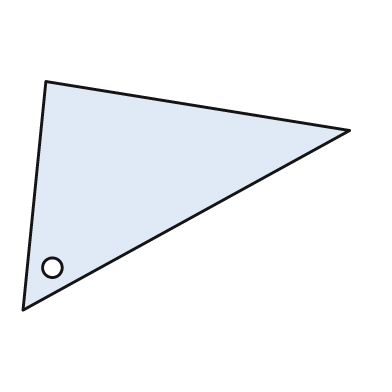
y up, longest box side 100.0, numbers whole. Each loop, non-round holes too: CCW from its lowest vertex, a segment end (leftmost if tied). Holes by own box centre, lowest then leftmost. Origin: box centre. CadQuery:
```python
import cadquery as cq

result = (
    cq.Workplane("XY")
    .moveTo(-50.0, -35.0)
    .lineTo(50.0, 20.0)
    .lineTo(-43.0, 35.0)
    .close()
    .moveTo(-41.0, -22.0)
    .circle(3.0)
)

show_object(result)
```